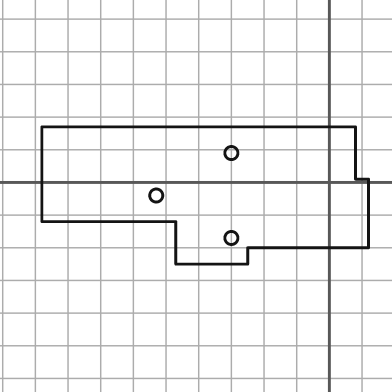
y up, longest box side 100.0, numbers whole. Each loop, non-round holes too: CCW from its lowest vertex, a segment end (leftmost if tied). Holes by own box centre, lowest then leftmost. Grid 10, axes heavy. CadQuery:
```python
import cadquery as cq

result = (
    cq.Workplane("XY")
    .moveTo(-47.0, -25.0)
    .lineTo(-25.0, -25.0)
    .lineTo(-25.0, -20.0)
    .lineTo(12.0, -20.0)
    .lineTo(12.0, 1.0)
    .lineTo(8.0, 1.0)
    .lineTo(8.0, 17.0)
    .lineTo(-88.0, 17.0)
    .lineTo(-88.0, -12.0)
    .lineTo(-47.0, -12.0)
    .close()
    .moveTo(-30.0, -17.0)
    .circle(2.0)
    .moveTo(-53.0, -4.0)
    .circle(2.0)
    .moveTo(-30.0, 9.0)
    .circle(2.0)
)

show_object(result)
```